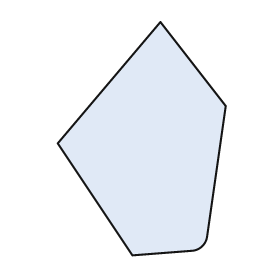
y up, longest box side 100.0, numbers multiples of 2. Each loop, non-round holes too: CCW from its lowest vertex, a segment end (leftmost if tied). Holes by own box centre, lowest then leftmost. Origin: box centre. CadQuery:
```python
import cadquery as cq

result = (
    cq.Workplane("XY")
    .moveTo(-4.0, -50.0)
    .lineTo(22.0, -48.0)
    .threePointArc((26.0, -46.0), (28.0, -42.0))
    .lineTo(36.0, 14.0)
    .lineTo(8.0, 50.0)
    .lineTo(-36.0, -2.0)
    .close()
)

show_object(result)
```